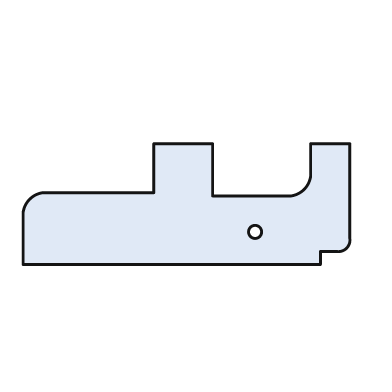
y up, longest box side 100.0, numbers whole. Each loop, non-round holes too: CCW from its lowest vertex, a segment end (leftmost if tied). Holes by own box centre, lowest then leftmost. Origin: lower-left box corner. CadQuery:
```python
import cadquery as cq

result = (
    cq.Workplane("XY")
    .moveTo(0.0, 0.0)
    .lineTo(91.0, 0.0)
    .lineTo(91.0, 4.0)
    .lineTo(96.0, 4.0)
    .threePointArc((99.0, 5.0), (100.0, 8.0))
    .lineTo(100.0, 37.0)
    .lineTo(88.0, 37.0)
    .lineTo(88.0, 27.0)
    .threePointArc((86.0, 23.0), (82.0, 21.0))
    .lineTo(58.0, 21.0)
    .lineTo(58.0, 37.0)
    .lineTo(40.0, 37.0)
    .lineTo(40.0, 22.0)
    .lineTo(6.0, 22.0)
    .threePointArc((2.0, 20.0), (0.0, 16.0))
    .close()
    .moveTo(71.0, 10.0)
    .circle(2.0)
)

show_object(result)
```